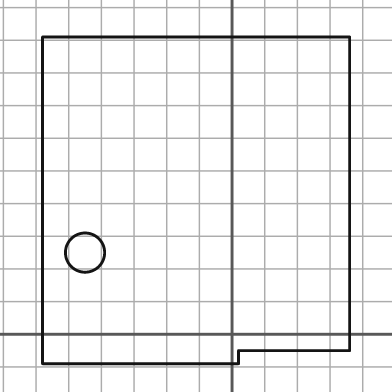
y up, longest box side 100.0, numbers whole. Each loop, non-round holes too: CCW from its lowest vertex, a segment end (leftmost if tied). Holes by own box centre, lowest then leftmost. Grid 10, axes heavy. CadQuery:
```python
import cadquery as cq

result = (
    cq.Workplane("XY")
    .moveTo(-58.0, -9.0)
    .lineTo(2.0, -9.0)
    .lineTo(2.0, -5.0)
    .lineTo(36.0, -5.0)
    .lineTo(36.0, 91.0)
    .lineTo(-58.0, 91.0)
    .close()
    .moveTo(-45.0, 25.0)
    .circle(6.0)
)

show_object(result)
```